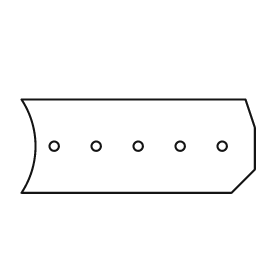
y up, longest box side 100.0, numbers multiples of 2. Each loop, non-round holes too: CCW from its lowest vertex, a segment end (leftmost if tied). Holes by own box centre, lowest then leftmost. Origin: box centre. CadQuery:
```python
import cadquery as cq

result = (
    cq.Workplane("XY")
    .moveTo(-50.0, -20.0)
    .lineTo(40.0, -20.0)
    .lineTo(50.0, -10.0)
    .lineTo(50.0, 8.0)
    .lineTo(46.0, 20.0)
    .lineTo(-50.0, 20.0)
    .threePointArc((-44.0, 0.0), (-50.0, -20.0))
    .close()
    .moveTo(-36.0, 0.0)
    .circle(2.0)
    .moveTo(-18.0, 0.0)
    .circle(2.0)
    .moveTo(0.0, 0.0)
    .circle(2.0)
    .moveTo(18.0, 0.0)
    .circle(2.0)
    .moveTo(36.0, 0.0)
    .circle(2.0)
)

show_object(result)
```